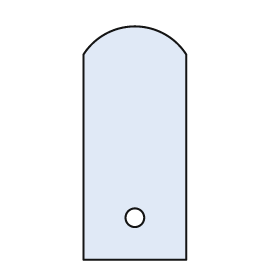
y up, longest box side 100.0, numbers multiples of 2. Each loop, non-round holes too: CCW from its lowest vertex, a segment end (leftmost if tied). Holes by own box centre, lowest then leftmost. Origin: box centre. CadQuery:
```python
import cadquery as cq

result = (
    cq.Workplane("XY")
    .moveTo(-22.0, -50.0)
    .lineTo(22.0, -50.0)
    .lineTo(22.0, 38.0)
    .threePointArc((0.0, 50.0), (-22.0, 38.0))
    .close()
    .moveTo(0.0, -32.0)
    .circle(4.0)
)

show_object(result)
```